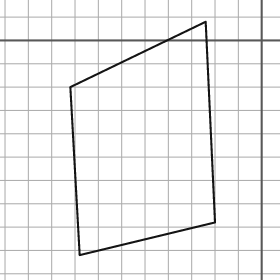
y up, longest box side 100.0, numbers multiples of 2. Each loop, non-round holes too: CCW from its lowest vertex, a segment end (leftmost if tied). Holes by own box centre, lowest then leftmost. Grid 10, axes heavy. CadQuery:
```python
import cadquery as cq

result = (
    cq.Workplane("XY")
    .moveTo(-78.0, -92.0)
    .lineTo(-20.0, -78.0)
    .lineTo(-24.0, 8.0)
    .lineTo(-82.0, -20.0)
    .close()
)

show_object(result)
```